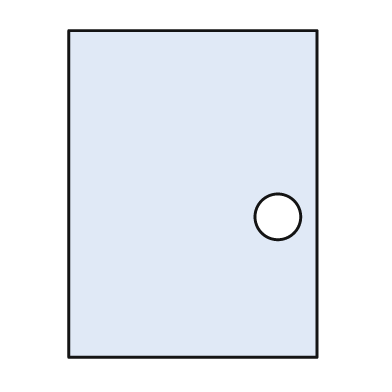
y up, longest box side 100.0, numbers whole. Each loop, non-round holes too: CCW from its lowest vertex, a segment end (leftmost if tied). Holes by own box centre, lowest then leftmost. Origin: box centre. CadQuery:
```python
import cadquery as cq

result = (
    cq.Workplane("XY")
    .moveTo(-38.0, -50.0)
    .lineTo(38.0, -50.0)
    .lineTo(38.0, 50.0)
    .lineTo(-38.0, 50.0)
    .close()
    .moveTo(26.0, -7.0)
    .circle(7.0)
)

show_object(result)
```